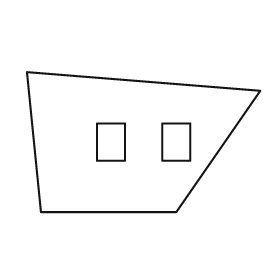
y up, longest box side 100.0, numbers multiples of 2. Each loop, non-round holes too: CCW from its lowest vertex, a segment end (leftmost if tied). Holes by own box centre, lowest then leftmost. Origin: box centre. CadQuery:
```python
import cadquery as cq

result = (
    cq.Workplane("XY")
    .moveTo(-44.0, -30.0)
    .lineTo(14.0, -30.0)
    .lineTo(50.0, 22.0)
    .lineTo(-50.0, 30.0)
    .close()
    .moveTo(-20.0, -8.0)
    .lineTo(-8.0, -8.0)
    .lineTo(-8.0, 8.0)
    .lineTo(-20.0, 8.0)
    .close()
    .moveTo(8.0, -8.0)
    .lineTo(20.0, -8.0)
    .lineTo(20.0, 8.0)
    .lineTo(8.0, 8.0)
    .close()
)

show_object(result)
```